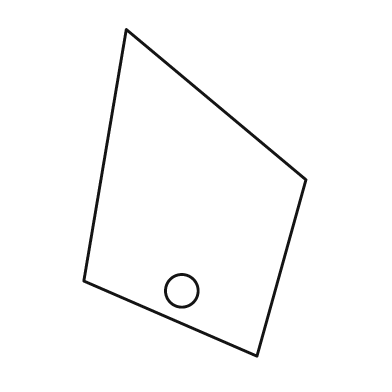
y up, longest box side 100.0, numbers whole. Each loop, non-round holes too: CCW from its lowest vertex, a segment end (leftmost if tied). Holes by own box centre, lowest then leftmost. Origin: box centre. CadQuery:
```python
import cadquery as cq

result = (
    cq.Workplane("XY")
    .moveTo(19.0, -50.0)
    .lineTo(34.0, 4.0)
    .lineTo(-21.0, 50.0)
    .lineTo(-34.0, -27.0)
    .close()
    .moveTo(-4.0, -30.0)
    .circle(5.0)
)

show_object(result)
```